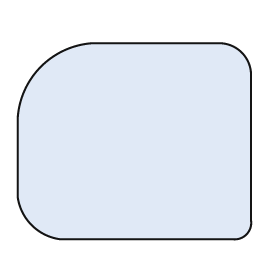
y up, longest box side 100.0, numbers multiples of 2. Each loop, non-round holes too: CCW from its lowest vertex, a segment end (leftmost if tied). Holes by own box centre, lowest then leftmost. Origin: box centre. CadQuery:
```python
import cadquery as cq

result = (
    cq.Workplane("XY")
    .moveTo(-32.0, -42.0)
    .lineTo(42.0, -42.0)
    .threePointArc((48.0, -40.0), (50.0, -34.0))
    .lineTo(50.0, 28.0)
    .threePointArc((46.0, 38.0), (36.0, 42.0))
    .lineTo(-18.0, 42.0)
    .threePointArc((-40.0, 32.0), (-50.0, 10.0))
    .lineTo(-50.0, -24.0)
    .threePointArc((-44.0, -36.0), (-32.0, -42.0))
    .close()
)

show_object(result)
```